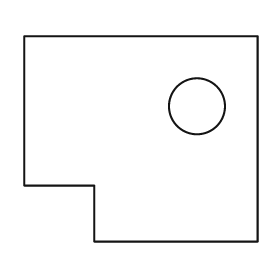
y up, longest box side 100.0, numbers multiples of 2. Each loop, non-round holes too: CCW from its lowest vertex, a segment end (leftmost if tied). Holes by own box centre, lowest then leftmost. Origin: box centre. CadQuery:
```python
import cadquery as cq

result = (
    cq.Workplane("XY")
    .moveTo(-20.0, -44.0)
    .lineTo(50.0, -44.0)
    .lineTo(50.0, 44.0)
    .lineTo(-50.0, 44.0)
    .lineTo(-50.0, -20.0)
    .lineTo(-20.0, -20.0)
    .close()
    .moveTo(24.0, 14.0)
    .circle(12.0)
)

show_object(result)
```